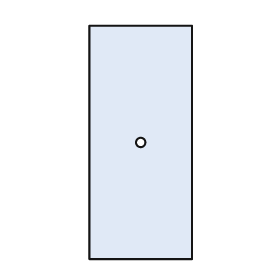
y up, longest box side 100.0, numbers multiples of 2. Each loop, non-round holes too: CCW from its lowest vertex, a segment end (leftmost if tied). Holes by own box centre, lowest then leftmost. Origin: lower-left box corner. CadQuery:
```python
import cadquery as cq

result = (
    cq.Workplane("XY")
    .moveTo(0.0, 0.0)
    .lineTo(44.0, 0.0)
    .lineTo(44.0, 100.0)
    .lineTo(0.0, 100.0)
    .close()
    .moveTo(22.0, 50.0)
    .circle(2.0)
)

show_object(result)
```